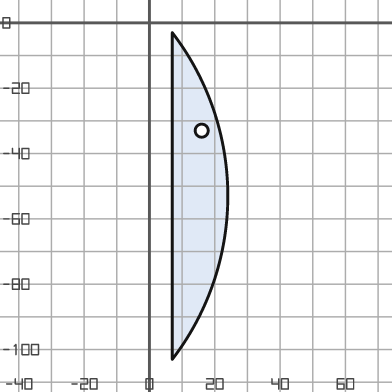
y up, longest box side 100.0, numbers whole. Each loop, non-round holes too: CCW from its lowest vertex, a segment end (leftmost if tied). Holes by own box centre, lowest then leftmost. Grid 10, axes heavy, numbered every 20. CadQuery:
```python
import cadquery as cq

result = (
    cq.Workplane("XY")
    .moveTo(7.0, -103.0)
    .threePointArc((24.0, -53.0), (7.0, -3.0))
    .close()
    .moveTo(16.0, -33.0)
    .circle(2.0)
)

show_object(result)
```